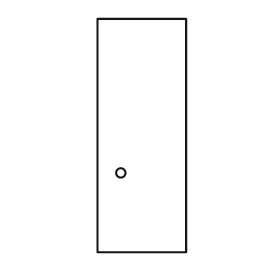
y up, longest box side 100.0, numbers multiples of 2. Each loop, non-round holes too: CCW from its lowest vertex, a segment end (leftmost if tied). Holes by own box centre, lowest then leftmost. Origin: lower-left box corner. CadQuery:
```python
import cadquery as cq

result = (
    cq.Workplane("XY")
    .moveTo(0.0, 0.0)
    .lineTo(38.0, 0.0)
    .lineTo(38.0, 100.0)
    .lineTo(0.0, 100.0)
    .close()
    .moveTo(10.0, 34.0)
    .circle(2.0)
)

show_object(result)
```